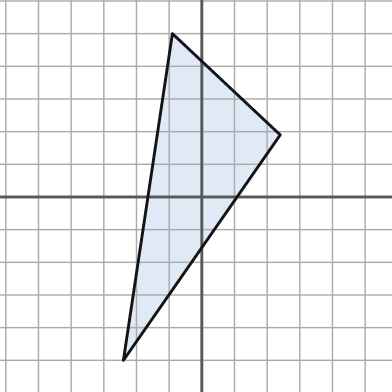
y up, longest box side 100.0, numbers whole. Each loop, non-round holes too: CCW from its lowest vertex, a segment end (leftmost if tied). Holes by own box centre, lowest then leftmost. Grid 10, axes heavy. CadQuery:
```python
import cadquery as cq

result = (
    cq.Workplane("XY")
    .moveTo(-24.0, -50.0)
    .lineTo(24.0, 19.0)
    .lineTo(-9.0, 50.0)
    .close()
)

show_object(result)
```